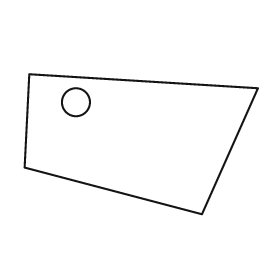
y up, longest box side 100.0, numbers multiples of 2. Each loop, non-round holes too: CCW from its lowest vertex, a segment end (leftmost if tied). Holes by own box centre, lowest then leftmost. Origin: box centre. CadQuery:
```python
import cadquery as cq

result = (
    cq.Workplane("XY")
    .moveTo(26.0, -30.0)
    .lineTo(50.0, 24.0)
    .lineTo(-48.0, 30.0)
    .lineTo(-50.0, -10.0)
    .close()
    .moveTo(-28.0, 18.0)
    .circle(6.0)
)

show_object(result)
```